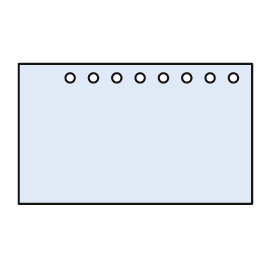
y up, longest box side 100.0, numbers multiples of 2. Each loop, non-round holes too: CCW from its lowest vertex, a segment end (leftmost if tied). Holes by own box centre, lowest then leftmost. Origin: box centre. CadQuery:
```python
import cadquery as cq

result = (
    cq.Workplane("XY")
    .moveTo(-50.0, -30.0)
    .lineTo(50.0, -30.0)
    .lineTo(50.0, 30.0)
    .lineTo(-50.0, 30.0)
    .close()
    .moveTo(-28.0, 24.0)
    .circle(2.0)
    .moveTo(-18.0, 24.0)
    .circle(2.0)
    .moveTo(-8.0, 24.0)
    .circle(2.0)
    .moveTo(2.0, 24.0)
    .circle(2.0)
    .moveTo(12.0, 24.0)
    .circle(2.0)
    .moveTo(22.0, 24.0)
    .circle(2.0)
    .moveTo(32.0, 24.0)
    .circle(2.0)
    .moveTo(42.0, 24.0)
    .circle(2.0)
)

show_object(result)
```